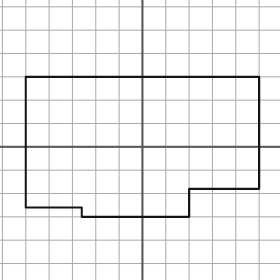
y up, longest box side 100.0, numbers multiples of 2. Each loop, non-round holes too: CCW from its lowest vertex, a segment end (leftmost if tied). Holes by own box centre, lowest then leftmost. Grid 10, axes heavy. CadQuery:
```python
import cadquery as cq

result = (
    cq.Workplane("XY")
    .moveTo(-26.0, -30.0)
    .lineTo(20.0, -30.0)
    .lineTo(20.0, -18.0)
    .lineTo(50.0, -18.0)
    .lineTo(50.0, 30.0)
    .lineTo(-50.0, 30.0)
    .lineTo(-50.0, -26.0)
    .lineTo(-26.0, -26.0)
    .close()
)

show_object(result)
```